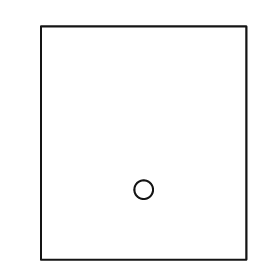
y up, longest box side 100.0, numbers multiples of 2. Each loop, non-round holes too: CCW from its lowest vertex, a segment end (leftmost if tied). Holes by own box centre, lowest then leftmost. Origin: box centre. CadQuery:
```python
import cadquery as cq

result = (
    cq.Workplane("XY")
    .moveTo(-44.0, -50.0)
    .lineTo(44.0, -50.0)
    .lineTo(44.0, 50.0)
    .lineTo(-44.0, 50.0)
    .close()
    .moveTo(0.0, -20.0)
    .circle(4.0)
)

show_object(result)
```